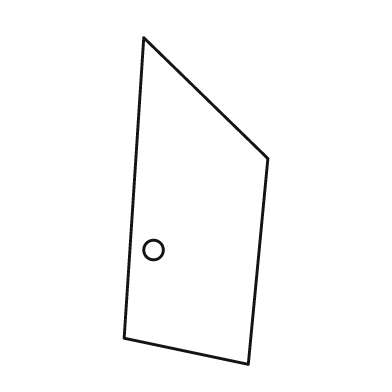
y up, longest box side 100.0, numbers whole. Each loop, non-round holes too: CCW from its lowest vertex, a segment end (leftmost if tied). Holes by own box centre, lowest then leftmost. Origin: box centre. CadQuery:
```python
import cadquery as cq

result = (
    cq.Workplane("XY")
    .moveTo(16.0, -50.0)
    .lineTo(22.0, 13.0)
    .lineTo(-16.0, 50.0)
    .lineTo(-22.0, -42.0)
    .close()
    .moveTo(-13.0, -15.0)
    .circle(3.0)
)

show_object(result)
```